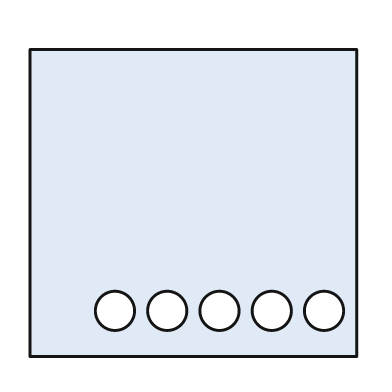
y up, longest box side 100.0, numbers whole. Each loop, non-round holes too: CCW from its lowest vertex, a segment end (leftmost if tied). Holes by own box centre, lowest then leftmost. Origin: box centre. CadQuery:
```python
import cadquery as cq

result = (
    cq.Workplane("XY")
    .moveTo(-50.0, -47.0)
    .lineTo(50.0, -47.0)
    .lineTo(50.0, 47.0)
    .lineTo(-50.0, 47.0)
    .close()
    .moveTo(-24.0, -33.0)
    .circle(6.0)
    .moveTo(-8.0, -33.0)
    .circle(6.0)
    .moveTo(8.0, -33.0)
    .circle(6.0)
    .moveTo(24.0, -33.0)
    .circle(6.0)
    .moveTo(40.0, -33.0)
    .circle(6.0)
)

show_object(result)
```